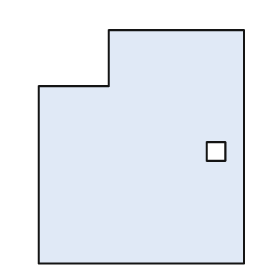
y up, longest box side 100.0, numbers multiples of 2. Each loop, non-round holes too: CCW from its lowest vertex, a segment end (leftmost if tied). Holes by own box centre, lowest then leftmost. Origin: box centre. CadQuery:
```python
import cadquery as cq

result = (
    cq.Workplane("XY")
    .moveTo(-44.0, -50.0)
    .lineTo(44.0, -50.0)
    .lineTo(44.0, 50.0)
    .lineTo(-14.0, 50.0)
    .lineTo(-14.0, 26.0)
    .lineTo(-44.0, 26.0)
    .close()
    .moveTo(28.0, -6.0)
    .lineTo(36.0, -6.0)
    .lineTo(36.0, 2.0)
    .lineTo(28.0, 2.0)
    .close()
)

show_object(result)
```